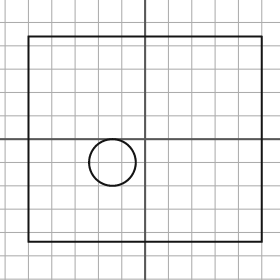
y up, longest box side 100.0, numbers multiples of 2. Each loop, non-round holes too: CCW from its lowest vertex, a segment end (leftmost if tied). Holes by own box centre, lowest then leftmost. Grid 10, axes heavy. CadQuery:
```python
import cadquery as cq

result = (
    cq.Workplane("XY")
    .moveTo(-50.0, -44.0)
    .lineTo(50.0, -44.0)
    .lineTo(50.0, 44.0)
    .lineTo(-50.0, 44.0)
    .close()
    .moveTo(-14.0, -10.0)
    .circle(10.0)
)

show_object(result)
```